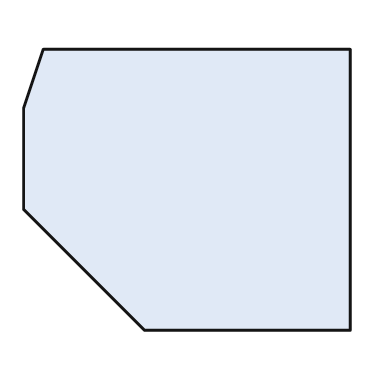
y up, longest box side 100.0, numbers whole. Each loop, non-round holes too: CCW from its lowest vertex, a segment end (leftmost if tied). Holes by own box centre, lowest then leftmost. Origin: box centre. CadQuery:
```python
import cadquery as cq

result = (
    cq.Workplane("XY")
    .moveTo(-13.0, -43.0)
    .lineTo(50.0, -43.0)
    .lineTo(50.0, 43.0)
    .lineTo(-44.0, 43.0)
    .lineTo(-50.0, 25.0)
    .lineTo(-50.0, -6.0)
    .close()
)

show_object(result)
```